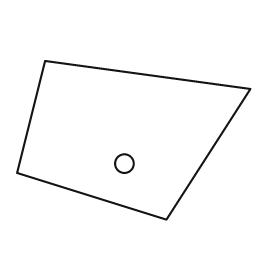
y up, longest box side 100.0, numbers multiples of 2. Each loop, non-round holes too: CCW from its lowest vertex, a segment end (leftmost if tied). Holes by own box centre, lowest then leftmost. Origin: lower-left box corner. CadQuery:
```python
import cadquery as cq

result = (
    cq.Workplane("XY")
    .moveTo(64.0, 0.0)
    .lineTo(100.0, 56.0)
    .lineTo(12.0, 68.0)
    .lineTo(0.0, 20.0)
    .close()
    .moveTo(46.0, 24.0)
    .circle(4.0)
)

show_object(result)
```